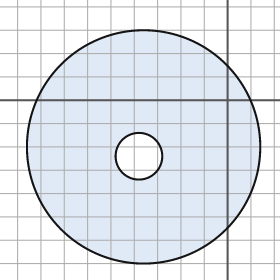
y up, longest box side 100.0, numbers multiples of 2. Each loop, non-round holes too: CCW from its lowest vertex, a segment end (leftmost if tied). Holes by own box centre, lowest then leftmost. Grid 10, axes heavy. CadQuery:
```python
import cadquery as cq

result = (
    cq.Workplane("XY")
    .moveTo(-36.0, -20.0)
    .circle(50.0)
    .moveTo(-38.0, -24.0)
    .circle(10.0)
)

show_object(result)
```